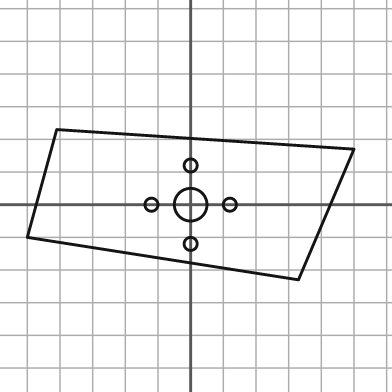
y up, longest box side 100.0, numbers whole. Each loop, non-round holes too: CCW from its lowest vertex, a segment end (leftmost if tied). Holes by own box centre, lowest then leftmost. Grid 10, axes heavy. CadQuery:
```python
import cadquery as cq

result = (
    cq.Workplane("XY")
    .moveTo(33.0, -23.0)
    .lineTo(50.0, 17.0)
    .lineTo(-41.0, 23.0)
    .lineTo(-50.0, -10.0)
    .close()
    .moveTo(0.0, -12.0)
    .circle(2.0)
    .moveTo(-12.0, 0.0)
    .circle(2.0)
    .moveTo(0.0, 0.0)
    .circle(5.0)
    .moveTo(12.0, 0.0)
    .circle(2.0)
    .moveTo(0.0, 12.0)
    .circle(2.0)
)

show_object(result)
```